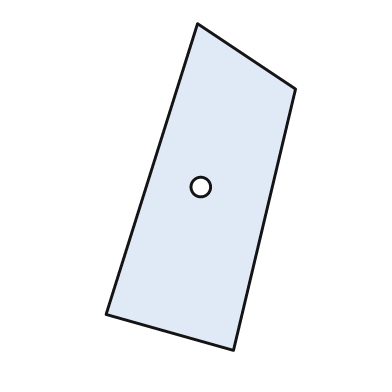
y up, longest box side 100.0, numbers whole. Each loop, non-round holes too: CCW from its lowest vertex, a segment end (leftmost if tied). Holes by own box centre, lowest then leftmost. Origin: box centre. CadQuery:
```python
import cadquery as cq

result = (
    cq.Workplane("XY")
    .moveTo(10.0, -50.0)
    .lineTo(29.0, 30.0)
    .lineTo(-1.0, 50.0)
    .lineTo(-29.0, -39.0)
    .close()
    .moveTo(0.0, 0.0)
    .circle(3.0)
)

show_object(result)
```